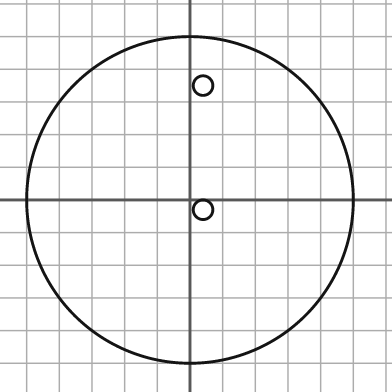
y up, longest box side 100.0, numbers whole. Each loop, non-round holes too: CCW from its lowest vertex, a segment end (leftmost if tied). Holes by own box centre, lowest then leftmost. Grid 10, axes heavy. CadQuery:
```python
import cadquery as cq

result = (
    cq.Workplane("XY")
    .moveTo(0.0, 0.0)
    .circle(50.0)
    .moveTo(4.0, -3.0)
    .circle(3.0)
    .moveTo(4.0, 35.0)
    .circle(3.0)
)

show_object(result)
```